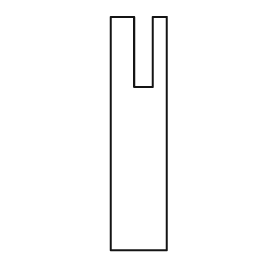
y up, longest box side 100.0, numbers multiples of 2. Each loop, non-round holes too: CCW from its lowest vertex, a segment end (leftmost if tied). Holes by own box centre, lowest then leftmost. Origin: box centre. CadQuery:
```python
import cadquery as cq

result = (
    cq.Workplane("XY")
    .moveTo(-12.0, -50.0)
    .lineTo(12.0, -50.0)
    .lineTo(12.0, 50.0)
    .lineTo(6.0, 50.0)
    .lineTo(6.0, 20.0)
    .lineTo(-2.0, 20.0)
    .lineTo(-2.0, 50.0)
    .lineTo(-12.0, 50.0)
    .close()
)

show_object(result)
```